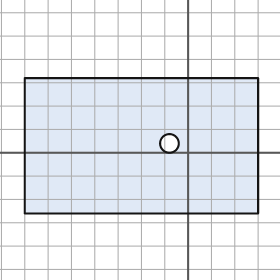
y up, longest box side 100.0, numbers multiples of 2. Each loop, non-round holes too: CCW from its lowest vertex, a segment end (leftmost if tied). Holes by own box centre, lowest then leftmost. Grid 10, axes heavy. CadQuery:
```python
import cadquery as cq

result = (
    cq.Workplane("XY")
    .moveTo(-70.0, -26.0)
    .lineTo(30.0, -26.0)
    .lineTo(30.0, 32.0)
    .lineTo(-70.0, 32.0)
    .close()
    .moveTo(-8.0, 4.0)
    .circle(4.0)
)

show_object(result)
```